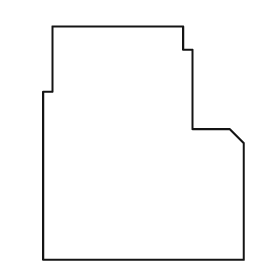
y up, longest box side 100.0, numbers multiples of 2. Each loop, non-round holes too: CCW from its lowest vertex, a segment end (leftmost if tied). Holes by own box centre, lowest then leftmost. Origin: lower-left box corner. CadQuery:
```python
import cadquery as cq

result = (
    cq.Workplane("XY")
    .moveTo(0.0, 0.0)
    .lineTo(86.0, 0.0)
    .lineTo(86.0, 50.0)
    .lineTo(80.0, 56.0)
    .lineTo(64.0, 56.0)
    .lineTo(64.0, 90.0)
    .lineTo(60.0, 90.0)
    .lineTo(60.0, 100.0)
    .lineTo(4.0, 100.0)
    .lineTo(4.0, 72.0)
    .lineTo(0.0, 72.0)
    .close()
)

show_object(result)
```